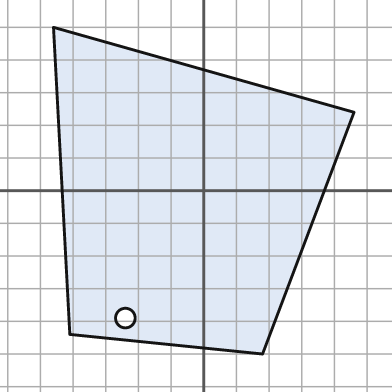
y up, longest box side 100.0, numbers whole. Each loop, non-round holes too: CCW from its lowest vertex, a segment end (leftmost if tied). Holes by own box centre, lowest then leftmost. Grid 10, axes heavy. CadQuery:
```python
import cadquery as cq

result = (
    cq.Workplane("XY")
    .moveTo(18.0, -50.0)
    .lineTo(46.0, 24.0)
    .lineTo(-46.0, 50.0)
    .lineTo(-41.0, -44.0)
    .close()
    .moveTo(-24.0, -39.0)
    .circle(3.0)
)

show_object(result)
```